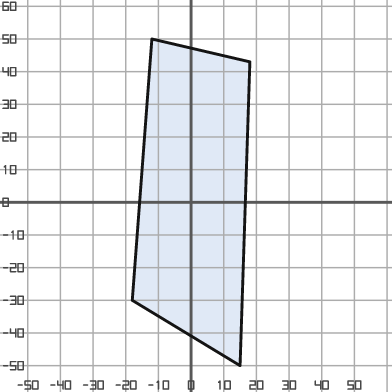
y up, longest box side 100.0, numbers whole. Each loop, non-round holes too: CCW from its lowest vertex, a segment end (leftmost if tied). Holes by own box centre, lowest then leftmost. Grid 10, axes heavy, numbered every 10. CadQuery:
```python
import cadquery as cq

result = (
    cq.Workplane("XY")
    .moveTo(15.0, -50.0)
    .lineTo(18.0, 43.0)
    .lineTo(-12.0, 50.0)
    .lineTo(-18.0, -30.0)
    .close()
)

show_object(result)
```